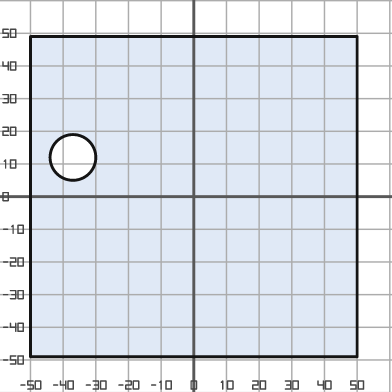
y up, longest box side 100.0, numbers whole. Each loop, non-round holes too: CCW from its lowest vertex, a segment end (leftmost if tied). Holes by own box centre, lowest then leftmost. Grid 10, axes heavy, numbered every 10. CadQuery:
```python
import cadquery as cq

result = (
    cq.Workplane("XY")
    .moveTo(-50.0, -49.0)
    .lineTo(50.0, -49.0)
    .lineTo(50.0, 49.0)
    .lineTo(-50.0, 49.0)
    .close()
    .moveTo(-37.0, 12.0)
    .circle(7.0)
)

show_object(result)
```